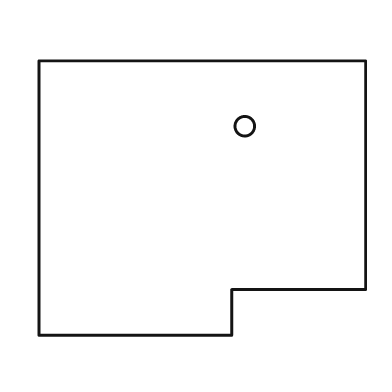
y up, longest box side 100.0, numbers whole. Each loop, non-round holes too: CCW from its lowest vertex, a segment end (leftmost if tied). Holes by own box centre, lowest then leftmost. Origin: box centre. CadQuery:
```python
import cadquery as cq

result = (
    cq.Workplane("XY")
    .moveTo(-50.0, -42.0)
    .lineTo(9.0, -42.0)
    .lineTo(9.0, -28.0)
    .lineTo(50.0, -28.0)
    .lineTo(50.0, 42.0)
    .lineTo(-50.0, 42.0)
    .close()
    .moveTo(13.0, 22.0)
    .circle(3.0)
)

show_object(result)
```